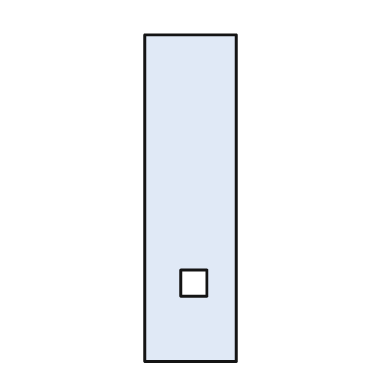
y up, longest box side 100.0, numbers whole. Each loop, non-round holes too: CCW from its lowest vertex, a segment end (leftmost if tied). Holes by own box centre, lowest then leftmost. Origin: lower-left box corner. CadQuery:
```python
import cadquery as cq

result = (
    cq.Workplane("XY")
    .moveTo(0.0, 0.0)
    .lineTo(28.0, 0.0)
    .lineTo(28.0, 100.0)
    .lineTo(0.0, 100.0)
    .close()
    .moveTo(11.0, 20.0)
    .lineTo(19.0, 20.0)
    .lineTo(19.0, 28.0)
    .lineTo(11.0, 28.0)
    .close()
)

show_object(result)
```